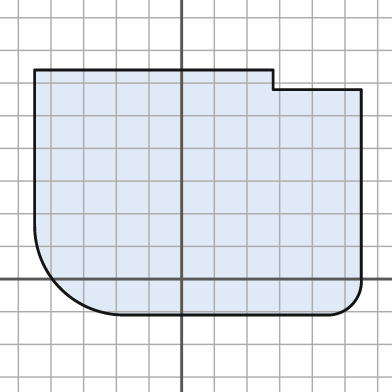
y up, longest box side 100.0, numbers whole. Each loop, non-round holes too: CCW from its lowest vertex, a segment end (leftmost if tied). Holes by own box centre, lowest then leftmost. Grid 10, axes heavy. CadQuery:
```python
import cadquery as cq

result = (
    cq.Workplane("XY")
    .moveTo(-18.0, -11.0)
    .lineTo(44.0, -11.0)
    .threePointArc((52.0, -8.0), (55.0, 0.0))
    .lineTo(55.0, 58.0)
    .lineTo(28.0, 58.0)
    .lineTo(28.0, 64.0)
    .lineTo(-45.0, 64.0)
    .lineTo(-45.0, 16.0)
    .threePointArc((-37.0, -3.0), (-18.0, -11.0))
    .close()
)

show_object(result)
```